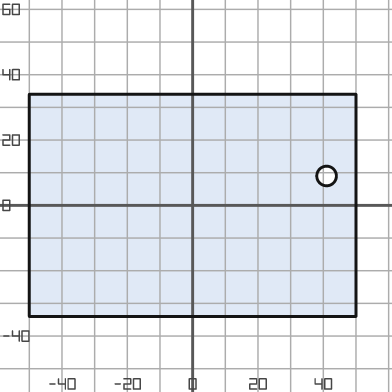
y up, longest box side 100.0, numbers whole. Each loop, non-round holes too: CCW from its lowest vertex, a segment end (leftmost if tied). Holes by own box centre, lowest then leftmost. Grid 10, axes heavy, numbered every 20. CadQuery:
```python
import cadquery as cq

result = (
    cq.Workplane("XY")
    .moveTo(-50.0, -34.0)
    .lineTo(50.0, -34.0)
    .lineTo(50.0, 34.0)
    .lineTo(-50.0, 34.0)
    .close()
    .moveTo(41.0, 9.0)
    .circle(3.0)
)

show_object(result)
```